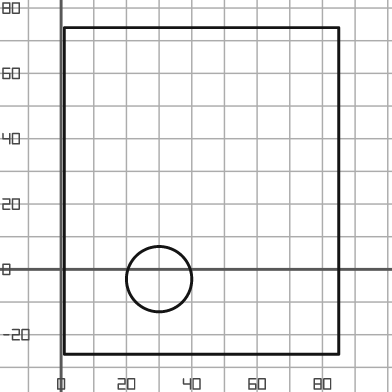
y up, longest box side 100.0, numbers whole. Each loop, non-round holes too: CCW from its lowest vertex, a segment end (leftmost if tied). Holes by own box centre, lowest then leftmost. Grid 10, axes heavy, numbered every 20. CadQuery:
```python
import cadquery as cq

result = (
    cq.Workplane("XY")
    .moveTo(1.0, -26.0)
    .lineTo(85.0, -26.0)
    .lineTo(85.0, 74.0)
    .lineTo(1.0, 74.0)
    .close()
    .moveTo(30.0, -3.0)
    .circle(10.0)
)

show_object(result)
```